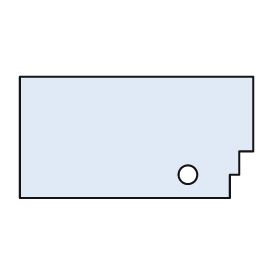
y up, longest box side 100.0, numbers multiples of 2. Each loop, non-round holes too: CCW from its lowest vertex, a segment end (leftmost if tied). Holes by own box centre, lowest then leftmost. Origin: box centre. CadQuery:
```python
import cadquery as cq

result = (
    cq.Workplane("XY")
    .moveTo(-50.0, -26.0)
    .lineTo(40.0, -26.0)
    .lineTo(40.0, -16.0)
    .lineTo(44.0, -16.0)
    .lineTo(44.0, -6.0)
    .lineTo(50.0, -6.0)
    .lineTo(50.0, 26.0)
    .lineTo(-50.0, 26.0)
    .close()
    .moveTo(22.0, -16.0)
    .circle(4.0)
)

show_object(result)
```